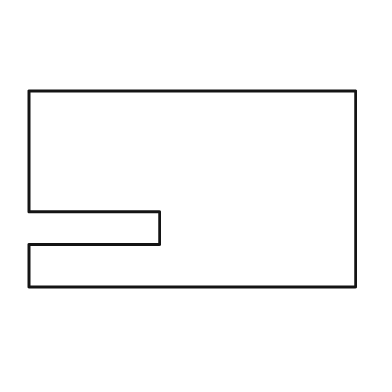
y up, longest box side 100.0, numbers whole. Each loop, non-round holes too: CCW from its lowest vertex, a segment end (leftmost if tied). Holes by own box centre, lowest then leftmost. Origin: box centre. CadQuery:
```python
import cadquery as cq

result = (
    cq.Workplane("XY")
    .moveTo(-50.0, -30.0)
    .lineTo(50.0, -30.0)
    .lineTo(50.0, 30.0)
    .lineTo(-50.0, 30.0)
    .lineTo(-50.0, -7.0)
    .lineTo(-10.0, -7.0)
    .lineTo(-10.0, -17.0)
    .lineTo(-50.0, -17.0)
    .close()
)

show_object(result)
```